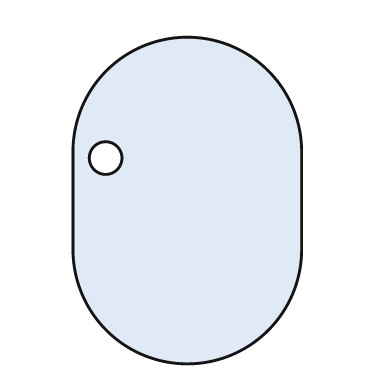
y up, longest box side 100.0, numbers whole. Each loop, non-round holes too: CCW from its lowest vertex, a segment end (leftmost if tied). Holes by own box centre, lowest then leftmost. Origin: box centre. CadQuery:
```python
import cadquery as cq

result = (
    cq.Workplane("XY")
    .moveTo(-35.0, -15.0)
    .threePointArc((0.0, -50.0), (35.0, -15.0))
    .lineTo(35.0, 15.0)
    .threePointArc((0.0, 50.0), (-35.0, 15.0))
    .close()
    .moveTo(-25.0, 13.0)
    .circle(5.0)
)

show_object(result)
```